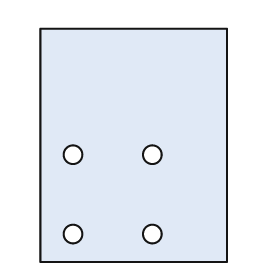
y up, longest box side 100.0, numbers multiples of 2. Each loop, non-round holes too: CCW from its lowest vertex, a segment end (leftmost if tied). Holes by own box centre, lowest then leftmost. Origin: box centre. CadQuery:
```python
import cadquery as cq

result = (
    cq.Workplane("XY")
    .moveTo(-40.0, -50.0)
    .lineTo(40.0, -50.0)
    .lineTo(40.0, 50.0)
    .lineTo(-40.0, 50.0)
    .close()
    .moveTo(-26.0, -38.0)
    .circle(4.0)
    .moveTo(8.0, -38.0)
    .circle(4.0)
    .moveTo(-26.0, -4.0)
    .circle(4.0)
    .moveTo(8.0, -4.0)
    .circle(4.0)
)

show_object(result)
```